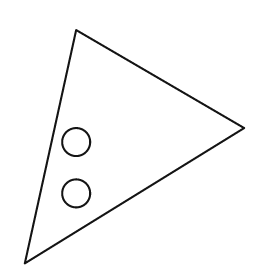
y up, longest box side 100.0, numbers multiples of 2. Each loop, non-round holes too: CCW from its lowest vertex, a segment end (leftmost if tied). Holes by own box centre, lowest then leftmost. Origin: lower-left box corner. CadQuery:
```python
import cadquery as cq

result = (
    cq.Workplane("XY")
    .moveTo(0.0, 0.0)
    .lineTo(94.0, 58.0)
    .lineTo(22.0, 100.0)
    .close()
    .moveTo(22.0, 30.0)
    .circle(6.0)
    .moveTo(22.0, 52.0)
    .circle(6.0)
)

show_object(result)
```